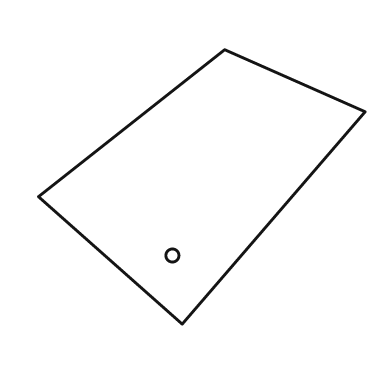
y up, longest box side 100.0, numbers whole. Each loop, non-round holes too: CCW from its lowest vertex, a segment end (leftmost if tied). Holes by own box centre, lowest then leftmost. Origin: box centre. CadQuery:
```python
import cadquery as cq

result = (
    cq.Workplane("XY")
    .moveTo(-6.0, -42.0)
    .lineTo(50.0, 23.0)
    .lineTo(7.0, 42.0)
    .lineTo(-50.0, -3.0)
    .close()
    .moveTo(-9.0, -21.0)
    .circle(2.0)
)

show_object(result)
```